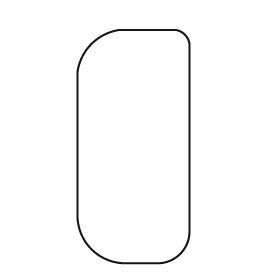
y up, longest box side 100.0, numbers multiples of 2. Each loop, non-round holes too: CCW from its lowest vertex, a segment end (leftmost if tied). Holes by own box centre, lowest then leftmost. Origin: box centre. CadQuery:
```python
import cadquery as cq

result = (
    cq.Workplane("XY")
    .moveTo(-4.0, -50.0)
    .lineTo(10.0, -50.0)
    .threePointArc((20.0, -46.0), (24.0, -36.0))
    .lineTo(24.0, 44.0)
    .threePointArc((22.0, 48.0), (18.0, 50.0))
    .lineTo(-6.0, 50.0)
    .threePointArc((-18.0, 44.0), (-24.0, 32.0))
    .lineTo(-24.0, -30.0)
    .threePointArc((-18.0, -44.0), (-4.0, -50.0))
    .close()
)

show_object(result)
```